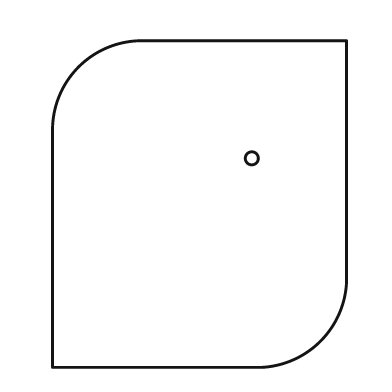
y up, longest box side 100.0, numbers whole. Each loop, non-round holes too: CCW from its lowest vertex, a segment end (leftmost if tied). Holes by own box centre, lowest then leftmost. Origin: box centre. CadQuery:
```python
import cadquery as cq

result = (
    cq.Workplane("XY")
    .moveTo(-45.0, -50.0)
    .lineTo(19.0, -50.0)
    .threePointArc((37.0, -42.0), (45.0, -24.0))
    .lineTo(45.0, 50.0)
    .lineTo(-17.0, 50.0)
    .threePointArc((-37.0, 42.0), (-45.0, 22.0))
    .close()
    .moveTo(16.0, 14.0)
    .circle(2.0)
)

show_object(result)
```